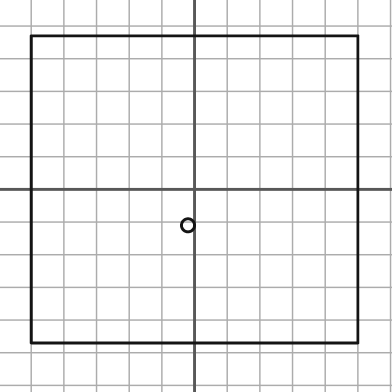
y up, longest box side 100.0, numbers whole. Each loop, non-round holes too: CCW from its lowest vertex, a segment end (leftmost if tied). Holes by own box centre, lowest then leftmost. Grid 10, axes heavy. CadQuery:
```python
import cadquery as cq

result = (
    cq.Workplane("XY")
    .moveTo(-50.0, -47.0)
    .lineTo(50.0, -47.0)
    .lineTo(50.0, 47.0)
    .lineTo(-50.0, 47.0)
    .close()
    .moveTo(-2.0, -11.0)
    .circle(2.0)
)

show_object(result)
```